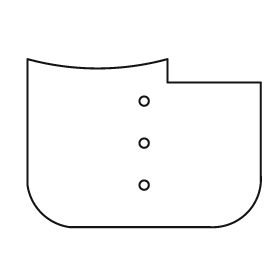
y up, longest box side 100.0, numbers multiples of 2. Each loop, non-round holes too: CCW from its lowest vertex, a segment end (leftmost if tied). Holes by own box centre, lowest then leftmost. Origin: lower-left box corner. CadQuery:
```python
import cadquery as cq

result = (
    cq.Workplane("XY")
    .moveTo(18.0, 0.0)
    .lineTo(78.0, 0.0)
    .threePointArc((94.0, 6.0), (100.0, 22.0))
    .lineTo(100.0, 62.0)
    .lineTo(60.0, 62.0)
    .lineTo(60.0, 72.0)
    .threePointArc((30.0, 68.0), (0.0, 72.0))
    .lineTo(0.0, 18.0)
    .threePointArc((6.0, 6.0), (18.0, 0.0))
    .close()
    .moveTo(50.0, 18.0)
    .circle(2.0)
    .moveTo(50.0, 36.0)
    .circle(2.0)
    .moveTo(50.0, 54.0)
    .circle(2.0)
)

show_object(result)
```